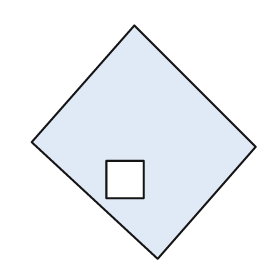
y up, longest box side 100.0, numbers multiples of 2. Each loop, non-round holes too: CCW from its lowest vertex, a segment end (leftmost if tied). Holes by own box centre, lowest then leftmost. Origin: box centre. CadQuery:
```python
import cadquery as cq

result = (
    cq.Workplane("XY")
    .moveTo(6.0, -50.0)
    .lineTo(48.0, -2.0)
    .lineTo(-4.0, 50.0)
    .lineTo(-48.0, 0.0)
    .close()
    .moveTo(-16.0, -24.0)
    .lineTo(0.0, -24.0)
    .lineTo(0.0, -8.0)
    .lineTo(-16.0, -8.0)
    .close()
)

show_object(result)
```